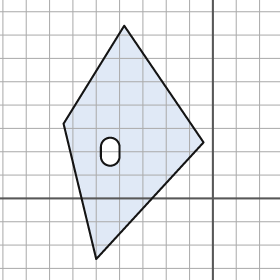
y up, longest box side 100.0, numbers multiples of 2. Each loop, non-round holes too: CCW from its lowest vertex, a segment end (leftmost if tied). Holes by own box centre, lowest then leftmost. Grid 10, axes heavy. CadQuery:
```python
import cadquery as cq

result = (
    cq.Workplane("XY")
    .moveTo(-50.0, -26.0)
    .lineTo(-4.0, 24.0)
    .lineTo(-38.0, 74.0)
    .lineTo(-64.0, 32.0)
    .close()
    .moveTo(-48.0, 18.0)
    .threePointArc((-44.0, 14.0), (-40.0, 18.0))
    .lineTo(-40.0, 22.0)
    .threePointArc((-44.0, 26.0), (-48.0, 22.0))
    .close()
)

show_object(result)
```